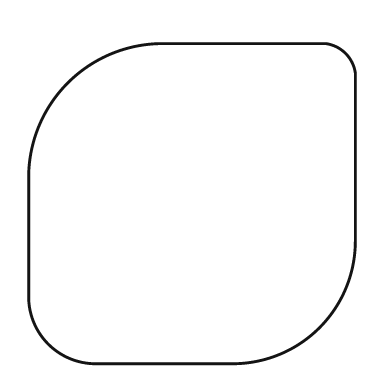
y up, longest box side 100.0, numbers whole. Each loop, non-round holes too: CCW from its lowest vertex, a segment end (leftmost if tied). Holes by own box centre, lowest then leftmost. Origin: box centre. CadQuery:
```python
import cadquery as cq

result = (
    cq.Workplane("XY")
    .moveTo(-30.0, -49.0)
    .lineTo(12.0, -49.0)
    .threePointArc((39.0, -38.0), (50.0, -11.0))
    .lineTo(50.0, 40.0)
    .threePointArc((47.0, 46.0), (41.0, 49.0))
    .lineTo(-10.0, 49.0)
    .threePointArc((-38.0, 37.0), (-50.0, 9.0))
    .lineTo(-50.0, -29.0)
    .threePointArc((-44.0, -43.0), (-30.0, -49.0))
    .close()
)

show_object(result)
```